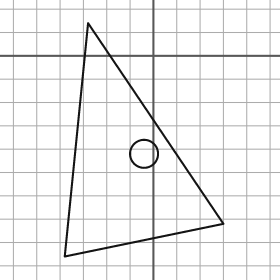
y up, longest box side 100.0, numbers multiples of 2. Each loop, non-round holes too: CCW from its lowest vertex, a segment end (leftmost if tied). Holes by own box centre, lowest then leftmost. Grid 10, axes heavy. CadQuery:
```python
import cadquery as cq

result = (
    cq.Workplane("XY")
    .moveTo(-38.0, -86.0)
    .lineTo(30.0, -72.0)
    .lineTo(-28.0, 14.0)
    .close()
    .moveTo(-4.0, -42.0)
    .circle(6.0)
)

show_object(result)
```